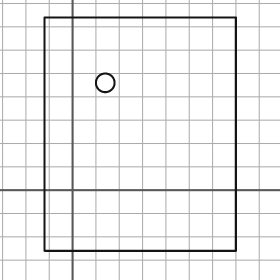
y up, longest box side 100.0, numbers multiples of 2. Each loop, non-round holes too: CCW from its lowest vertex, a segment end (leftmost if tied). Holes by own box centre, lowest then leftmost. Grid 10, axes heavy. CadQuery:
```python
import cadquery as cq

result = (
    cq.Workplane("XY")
    .moveTo(-12.0, -26.0)
    .lineTo(70.0, -26.0)
    .lineTo(70.0, 74.0)
    .lineTo(-12.0, 74.0)
    .close()
    .moveTo(14.0, 46.0)
    .circle(4.0)
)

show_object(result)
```